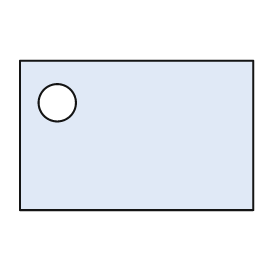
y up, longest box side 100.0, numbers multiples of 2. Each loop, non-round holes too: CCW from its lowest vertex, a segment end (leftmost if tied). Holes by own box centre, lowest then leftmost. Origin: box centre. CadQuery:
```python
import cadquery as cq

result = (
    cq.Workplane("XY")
    .moveTo(-50.0, -32.0)
    .lineTo(50.0, -32.0)
    .lineTo(50.0, 32.0)
    .lineTo(-50.0, 32.0)
    .close()
    .moveTo(-34.0, 14.0)
    .circle(8.0)
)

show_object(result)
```